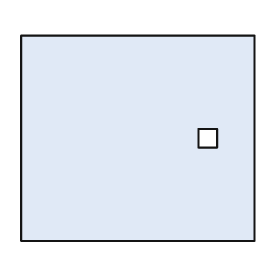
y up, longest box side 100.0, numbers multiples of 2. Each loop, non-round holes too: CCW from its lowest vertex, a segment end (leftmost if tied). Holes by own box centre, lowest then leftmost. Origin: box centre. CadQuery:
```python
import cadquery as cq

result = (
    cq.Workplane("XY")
    .moveTo(-50.0, -44.0)
    .lineTo(50.0, -44.0)
    .lineTo(50.0, 44.0)
    .lineTo(-50.0, 44.0)
    .close()
    .moveTo(26.0, -4.0)
    .lineTo(34.0, -4.0)
    .lineTo(34.0, 4.0)
    .lineTo(26.0, 4.0)
    .close()
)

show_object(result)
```